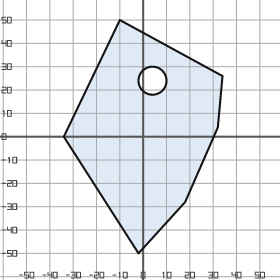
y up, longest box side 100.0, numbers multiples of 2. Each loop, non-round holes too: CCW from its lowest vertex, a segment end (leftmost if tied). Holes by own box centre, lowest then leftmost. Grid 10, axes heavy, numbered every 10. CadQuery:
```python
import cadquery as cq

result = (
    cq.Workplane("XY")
    .moveTo(-2.0, -50.0)
    .lineTo(18.0, -28.0)
    .lineTo(32.0, 4.0)
    .lineTo(34.0, 26.0)
    .lineTo(-10.0, 50.0)
    .lineTo(-34.0, 0.0)
    .close()
    .moveTo(4.0, 24.0)
    .circle(6.0)
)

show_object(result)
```